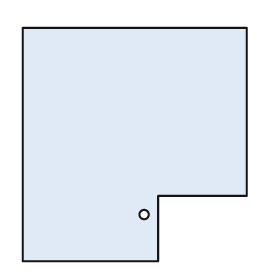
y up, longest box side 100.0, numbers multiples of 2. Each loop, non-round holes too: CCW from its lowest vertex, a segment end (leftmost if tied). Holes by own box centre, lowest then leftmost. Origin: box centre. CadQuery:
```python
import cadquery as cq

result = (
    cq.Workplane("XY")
    .moveTo(-48.0, -50.0)
    .lineTo(10.0, -50.0)
    .lineTo(10.0, -22.0)
    .lineTo(48.0, -22.0)
    .lineTo(48.0, 50.0)
    .lineTo(-48.0, 50.0)
    .close()
    .moveTo(4.0, -30.0)
    .circle(2.0)
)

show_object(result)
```